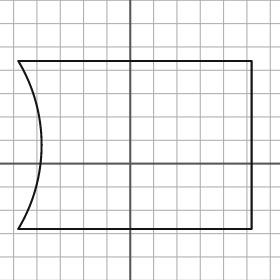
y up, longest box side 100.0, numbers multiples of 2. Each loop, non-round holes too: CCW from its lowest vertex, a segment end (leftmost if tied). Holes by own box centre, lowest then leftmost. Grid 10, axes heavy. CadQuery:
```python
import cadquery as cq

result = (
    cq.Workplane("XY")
    .moveTo(-48.0, -28.0)
    .lineTo(52.0, -28.0)
    .lineTo(52.0, 44.0)
    .lineTo(-48.0, 44.0)
    .threePointArc((-38.0, 8.0), (-48.0, -28.0))
    .close()
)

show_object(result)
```